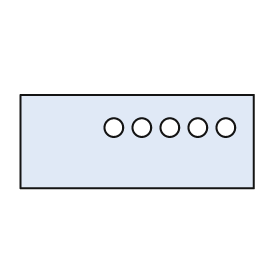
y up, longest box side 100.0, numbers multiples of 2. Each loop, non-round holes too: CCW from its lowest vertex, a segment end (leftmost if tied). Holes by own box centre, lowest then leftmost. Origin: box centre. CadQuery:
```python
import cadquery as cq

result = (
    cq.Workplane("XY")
    .moveTo(-50.0, -20.0)
    .lineTo(50.0, -20.0)
    .lineTo(50.0, 20.0)
    .lineTo(-50.0, 20.0)
    .close()
    .moveTo(-10.0, 6.0)
    .circle(4.0)
    .moveTo(2.0, 6.0)
    .circle(4.0)
    .moveTo(14.0, 6.0)
    .circle(4.0)
    .moveTo(26.0, 6.0)
    .circle(4.0)
    .moveTo(38.0, 6.0)
    .circle(4.0)
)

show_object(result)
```